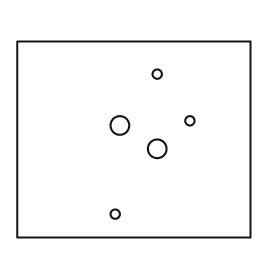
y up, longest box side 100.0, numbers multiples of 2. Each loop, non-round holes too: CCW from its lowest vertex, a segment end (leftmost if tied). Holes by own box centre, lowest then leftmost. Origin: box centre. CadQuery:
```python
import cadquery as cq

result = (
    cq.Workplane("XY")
    .moveTo(-50.0, -42.0)
    .lineTo(50.0, -42.0)
    .lineTo(50.0, 42.0)
    .lineTo(-50.0, 42.0)
    .close()
    .moveTo(-8.0, -32.0)
    .circle(2.0)
    .moveTo(10.0, -4.0)
    .circle(4.0)
    .moveTo(-6.0, 6.0)
    .circle(4.0)
    .moveTo(24.0, 8.0)
    .circle(2.0)
    .moveTo(10.0, 28.0)
    .circle(2.0)
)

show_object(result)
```